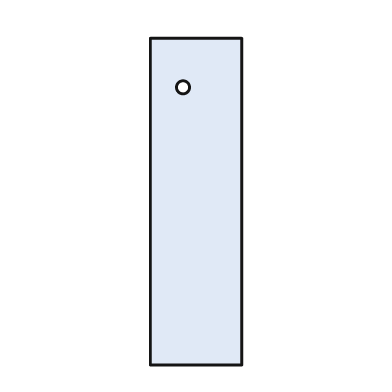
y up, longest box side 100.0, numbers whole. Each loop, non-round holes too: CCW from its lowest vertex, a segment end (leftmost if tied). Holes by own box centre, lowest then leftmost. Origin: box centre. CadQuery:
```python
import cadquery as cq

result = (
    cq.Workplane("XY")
    .moveTo(-14.0, -50.0)
    .lineTo(14.0, -50.0)
    .lineTo(14.0, 50.0)
    .lineTo(-14.0, 50.0)
    .close()
    .moveTo(-4.0, 35.0)
    .circle(2.0)
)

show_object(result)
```